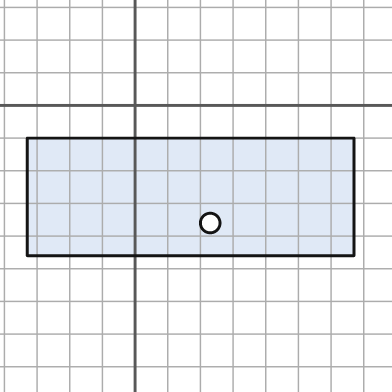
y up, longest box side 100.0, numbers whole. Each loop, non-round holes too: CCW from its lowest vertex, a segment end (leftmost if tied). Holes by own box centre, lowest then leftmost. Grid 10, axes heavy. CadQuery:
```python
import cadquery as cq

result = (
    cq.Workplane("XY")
    .moveTo(-33.0, -46.0)
    .lineTo(67.0, -46.0)
    .lineTo(67.0, -10.0)
    .lineTo(-33.0, -10.0)
    .close()
    .moveTo(23.0, -36.0)
    .circle(3.0)
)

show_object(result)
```